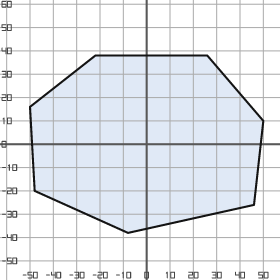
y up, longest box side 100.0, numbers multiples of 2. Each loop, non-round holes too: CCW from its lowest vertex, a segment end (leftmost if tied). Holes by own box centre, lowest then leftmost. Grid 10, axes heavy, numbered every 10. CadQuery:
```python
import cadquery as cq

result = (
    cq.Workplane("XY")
    .moveTo(-8.0, -38.0)
    .lineTo(46.0, -26.0)
    .lineTo(50.0, 10.0)
    .lineTo(26.0, 38.0)
    .lineTo(-22.0, 38.0)
    .lineTo(-50.0, 16.0)
    .lineTo(-48.0, -20.0)
    .close()
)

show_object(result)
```